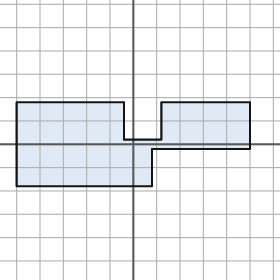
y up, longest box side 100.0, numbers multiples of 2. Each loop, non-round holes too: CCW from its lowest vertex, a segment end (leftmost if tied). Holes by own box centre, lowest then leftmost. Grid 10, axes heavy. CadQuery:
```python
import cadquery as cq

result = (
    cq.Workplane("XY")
    .moveTo(-50.0, -18.0)
    .lineTo(8.0, -18.0)
    .lineTo(8.0, -2.0)
    .lineTo(50.0, -2.0)
    .lineTo(50.0, 18.0)
    .lineTo(12.0, 18.0)
    .lineTo(12.0, 2.0)
    .lineTo(-4.0, 2.0)
    .lineTo(-4.0, 18.0)
    .lineTo(-50.0, 18.0)
    .close()
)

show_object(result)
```